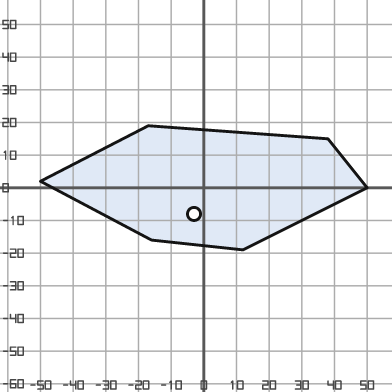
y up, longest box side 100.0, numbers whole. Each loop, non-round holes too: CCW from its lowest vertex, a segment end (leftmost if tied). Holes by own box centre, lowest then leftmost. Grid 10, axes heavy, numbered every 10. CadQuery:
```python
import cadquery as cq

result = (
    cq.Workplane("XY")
    .moveTo(12.0, -19.0)
    .lineTo(50.0, 0.0)
    .lineTo(38.0, 15.0)
    .lineTo(-17.0, 19.0)
    .lineTo(-50.0, 2.0)
    .lineTo(-16.0, -16.0)
    .close()
    .moveTo(-3.0, -8.0)
    .circle(2.0)
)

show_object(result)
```